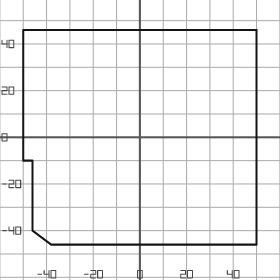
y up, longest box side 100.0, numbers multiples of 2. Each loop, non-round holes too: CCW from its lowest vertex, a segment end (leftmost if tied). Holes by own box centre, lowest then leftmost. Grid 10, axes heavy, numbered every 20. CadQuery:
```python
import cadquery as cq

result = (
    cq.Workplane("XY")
    .moveTo(-38.0, -46.0)
    .lineTo(50.0, -46.0)
    .lineTo(50.0, 46.0)
    .lineTo(-50.0, 46.0)
    .lineTo(-50.0, -10.0)
    .lineTo(-46.0, -10.0)
    .lineTo(-46.0, -40.0)
    .close()
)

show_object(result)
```